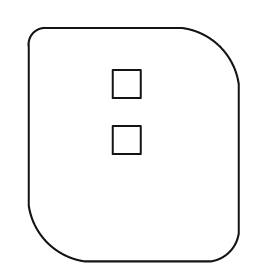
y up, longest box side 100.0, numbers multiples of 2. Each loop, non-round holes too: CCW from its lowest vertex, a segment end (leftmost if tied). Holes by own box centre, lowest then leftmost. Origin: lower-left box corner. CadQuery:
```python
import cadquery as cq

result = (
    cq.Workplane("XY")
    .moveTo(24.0, 0.0)
    .lineTo(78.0, 0.0)
    .threePointArc((86.0, 4.0), (90.0, 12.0))
    .lineTo(90.0, 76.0)
    .threePointArc((82.0, 92.0), (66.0, 100.0))
    .lineTo(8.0, 100.0)
    .threePointArc((2.0, 98.0), (0.0, 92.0))
    .lineTo(0.0, 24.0)
    .threePointArc((8.0, 8.0), (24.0, 0.0))
    .close()
    .moveTo(36.0, 46.0)
    .lineTo(48.0, 46.0)
    .lineTo(48.0, 58.0)
    .lineTo(36.0, 58.0)
    .close()
    .moveTo(36.0, 70.0)
    .lineTo(48.0, 70.0)
    .lineTo(48.0, 82.0)
    .lineTo(36.0, 82.0)
    .close()
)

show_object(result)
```